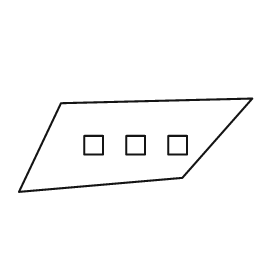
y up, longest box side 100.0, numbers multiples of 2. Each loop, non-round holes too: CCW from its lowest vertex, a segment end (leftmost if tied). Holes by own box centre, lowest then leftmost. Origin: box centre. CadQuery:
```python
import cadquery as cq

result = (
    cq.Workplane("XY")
    .moveTo(-50.0, -20.0)
    .lineTo(20.0, -14.0)
    .lineTo(50.0, 20.0)
    .lineTo(-32.0, 18.0)
    .close()
    .moveTo(-22.0, -4.0)
    .lineTo(-14.0, -4.0)
    .lineTo(-14.0, 4.0)
    .lineTo(-22.0, 4.0)
    .close()
    .moveTo(-4.0, -4.0)
    .lineTo(4.0, -4.0)
    .lineTo(4.0, 4.0)
    .lineTo(-4.0, 4.0)
    .close()
    .moveTo(14.0, -4.0)
    .lineTo(22.0, -4.0)
    .lineTo(22.0, 4.0)
    .lineTo(14.0, 4.0)
    .close()
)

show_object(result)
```